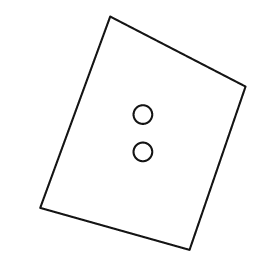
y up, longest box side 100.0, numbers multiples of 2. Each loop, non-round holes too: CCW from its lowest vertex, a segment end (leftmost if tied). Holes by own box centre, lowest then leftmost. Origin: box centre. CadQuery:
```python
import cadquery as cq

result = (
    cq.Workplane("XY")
    .moveTo(20.0, -50.0)
    .lineTo(44.0, 20.0)
    .lineTo(-14.0, 50.0)
    .lineTo(-44.0, -32.0)
    .close()
    .moveTo(0.0, -8.0)
    .circle(4.0)
    .moveTo(0.0, 8.0)
    .circle(4.0)
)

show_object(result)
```